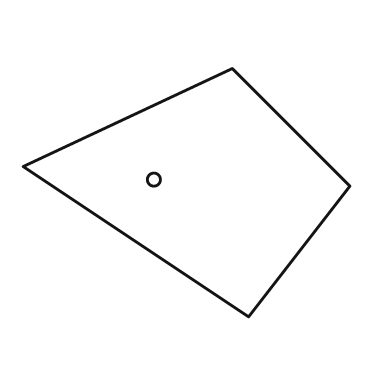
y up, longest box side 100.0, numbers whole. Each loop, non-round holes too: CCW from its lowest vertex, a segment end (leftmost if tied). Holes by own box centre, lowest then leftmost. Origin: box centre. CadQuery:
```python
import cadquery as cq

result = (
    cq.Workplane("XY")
    .moveTo(19.0, -38.0)
    .lineTo(50.0, 2.0)
    .lineTo(14.0, 38.0)
    .lineTo(-50.0, 8.0)
    .close()
    .moveTo(-10.0, 4.0)
    .circle(2.0)
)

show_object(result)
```